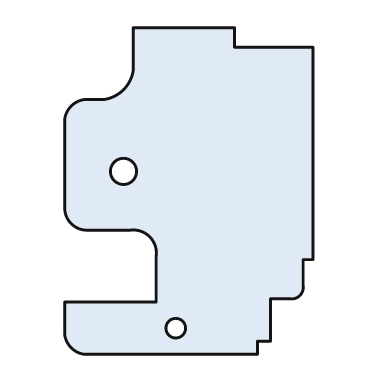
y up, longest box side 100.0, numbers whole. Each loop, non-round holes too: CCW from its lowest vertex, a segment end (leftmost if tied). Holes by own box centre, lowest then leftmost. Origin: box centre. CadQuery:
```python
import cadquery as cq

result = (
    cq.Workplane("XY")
    .moveTo(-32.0, -50.0)
    .lineTo(21.0, -50.0)
    .lineTo(21.0, -46.0)
    .lineTo(25.0, -46.0)
    .lineTo(25.0, -33.0)
    .lineTo(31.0, -33.0)
    .threePointArc((34.0, -32.0), (35.0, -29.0))
    .lineTo(35.0, -21.0)
    .lineTo(38.0, -21.0)
    .lineTo(38.0, 44.0)
    .lineTo(14.0, 44.0)
    .lineTo(14.0, 50.0)
    .lineTo(-17.0, 50.0)
    .lineTo(-17.0, 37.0)
    .threePointArc((-20.0, 31.0), (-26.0, 28.0))
    .lineTo(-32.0, 28.0)
    .threePointArc((-36.0, 26.0), (-38.0, 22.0))
    .lineTo(-38.0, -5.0)
    .threePointArc((-36.0, -10.0), (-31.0, -12.0))
    .lineTo(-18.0, -12.0)
    .threePointArc((-12.0, -14.0), (-10.0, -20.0))
    .lineTo(-10.0, -34.0)
    .lineTo(-38.0, -34.0)
    .lineTo(-38.0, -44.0)
    .threePointArc((-36.0, -48.0), (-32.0, -50.0))
    .close()
    .moveTo(-4.0, -42.0)
    .circle(3.0)
    .moveTo(-20.0, 6.0)
    .circle(4.0)
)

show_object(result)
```